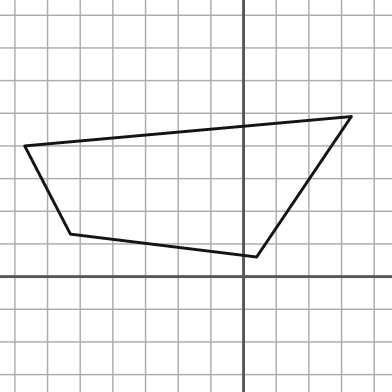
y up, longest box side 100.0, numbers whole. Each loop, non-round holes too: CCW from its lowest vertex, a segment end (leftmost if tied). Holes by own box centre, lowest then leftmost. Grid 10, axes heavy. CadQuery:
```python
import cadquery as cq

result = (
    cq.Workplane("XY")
    .moveTo(4.0, 6.0)
    .lineTo(33.0, 49.0)
    .lineTo(-67.0, 40.0)
    .lineTo(-53.0, 13.0)
    .close()
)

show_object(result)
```